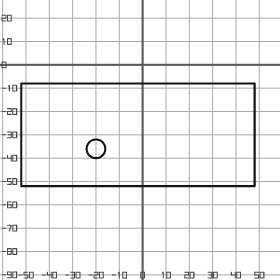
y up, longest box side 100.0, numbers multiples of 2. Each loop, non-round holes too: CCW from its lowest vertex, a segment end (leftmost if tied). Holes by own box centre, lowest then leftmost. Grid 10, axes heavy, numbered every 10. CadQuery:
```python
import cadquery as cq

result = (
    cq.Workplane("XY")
    .moveTo(-52.0, -52.0)
    .lineTo(48.0, -52.0)
    .lineTo(48.0, -8.0)
    .lineTo(-52.0, -8.0)
    .close()
    .moveTo(-20.0, -36.0)
    .circle(4.0)
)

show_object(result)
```